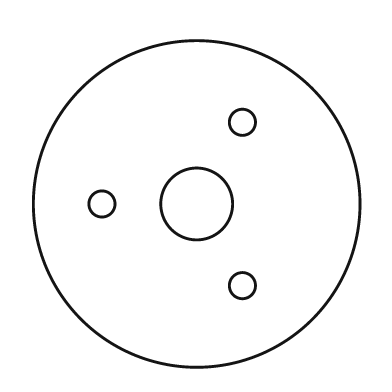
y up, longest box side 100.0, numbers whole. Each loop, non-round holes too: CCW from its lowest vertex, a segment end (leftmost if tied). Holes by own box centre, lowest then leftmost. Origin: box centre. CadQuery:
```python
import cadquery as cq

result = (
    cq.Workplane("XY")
    .moveTo(0.0, 0.0)
    .circle(50.0)
    .moveTo(14.0, -25.0)
    .circle(4.0)
    .moveTo(-29.0, 0.0)
    .circle(4.0)
    .moveTo(0.0, 0.0)
    .circle(11.0)
    .moveTo(14.0, 25.0)
    .circle(4.0)
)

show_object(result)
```